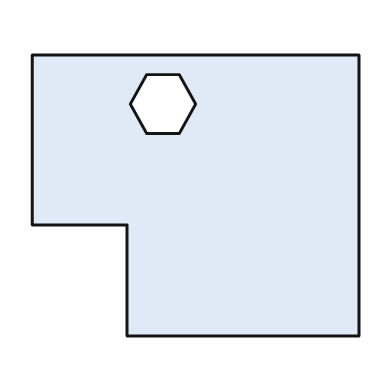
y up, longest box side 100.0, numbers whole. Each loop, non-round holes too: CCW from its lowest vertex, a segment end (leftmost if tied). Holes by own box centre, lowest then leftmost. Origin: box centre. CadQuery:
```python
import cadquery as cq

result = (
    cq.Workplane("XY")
    .moveTo(-21.0, -43.0)
    .lineTo(50.0, -43.0)
    .lineTo(50.0, 43.0)
    .lineTo(-50.0, 43.0)
    .lineTo(-50.0, -9.0)
    .lineTo(-21.0, -9.0)
    .close()
    .moveTo(-15.0, 19.0)
    .lineTo(-5.0, 19.0)
    .lineTo(0.0, 28.0)
    .lineTo(-5.0, 37.0)
    .lineTo(-15.0, 37.0)
    .lineTo(-20.0, 28.0)
    .close()
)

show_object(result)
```